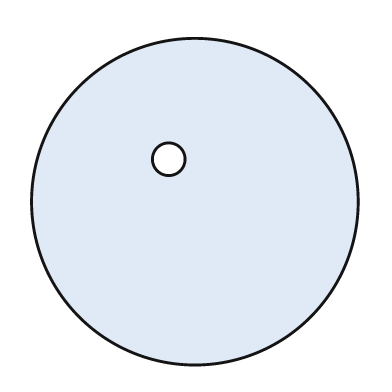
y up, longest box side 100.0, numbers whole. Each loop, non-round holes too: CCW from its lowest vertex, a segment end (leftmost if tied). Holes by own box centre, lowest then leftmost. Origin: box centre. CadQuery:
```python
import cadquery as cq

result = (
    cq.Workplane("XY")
    .moveTo(0.0, 0.0)
    .circle(50.0)
    .moveTo(-8.0, 13.0)
    .circle(5.0)
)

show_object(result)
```